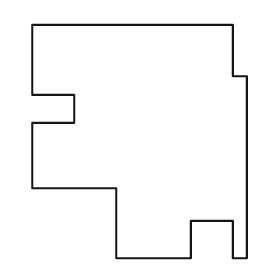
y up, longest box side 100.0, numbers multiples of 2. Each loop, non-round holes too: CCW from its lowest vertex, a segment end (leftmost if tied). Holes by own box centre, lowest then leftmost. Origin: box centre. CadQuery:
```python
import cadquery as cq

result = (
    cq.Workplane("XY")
    .moveTo(-10.0, -50.0)
    .lineTo(22.0, -50.0)
    .lineTo(22.0, -34.0)
    .lineTo(40.0, -34.0)
    .lineTo(40.0, -50.0)
    .lineTo(46.0, -50.0)
    .lineTo(46.0, 28.0)
    .lineTo(40.0, 28.0)
    .lineTo(40.0, 50.0)
    .lineTo(-46.0, 50.0)
    .lineTo(-46.0, 20.0)
    .lineTo(-28.0, 20.0)
    .lineTo(-28.0, 8.0)
    .lineTo(-46.0, 8.0)
    .lineTo(-46.0, -20.0)
    .lineTo(-10.0, -20.0)
    .close()
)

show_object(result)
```